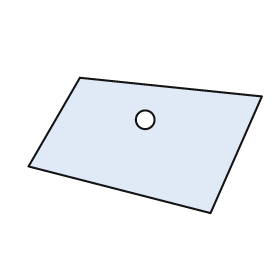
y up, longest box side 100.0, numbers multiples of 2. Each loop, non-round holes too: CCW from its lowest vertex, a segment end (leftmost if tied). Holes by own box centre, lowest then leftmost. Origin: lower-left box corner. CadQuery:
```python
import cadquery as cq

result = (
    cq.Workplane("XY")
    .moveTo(78.0, 0.0)
    .lineTo(100.0, 50.0)
    .lineTo(22.0, 58.0)
    .lineTo(0.0, 20.0)
    .close()
    .moveTo(50.0, 40.0)
    .circle(4.0)
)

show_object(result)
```